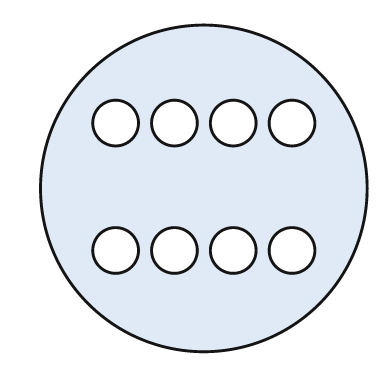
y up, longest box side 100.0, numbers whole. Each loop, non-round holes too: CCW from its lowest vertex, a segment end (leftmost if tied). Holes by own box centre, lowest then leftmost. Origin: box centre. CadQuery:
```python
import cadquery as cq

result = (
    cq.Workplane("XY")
    .moveTo(0.0, 0.0)
    .circle(50.0)
    .moveTo(-27.0, -19.0)
    .circle(7.0)
    .moveTo(-9.0, -19.0)
    .circle(7.0)
    .moveTo(9.0, -19.0)
    .circle(7.0)
    .moveTo(27.0, -19.0)
    .circle(7.0)
    .moveTo(-27.0, 20.0)
    .circle(7.0)
    .moveTo(-9.0, 20.0)
    .circle(7.0)
    .moveTo(9.0, 20.0)
    .circle(7.0)
    .moveTo(27.0, 20.0)
    .circle(7.0)
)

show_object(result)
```